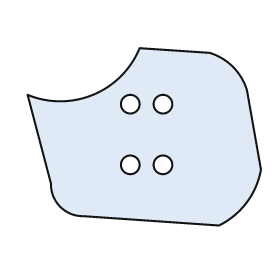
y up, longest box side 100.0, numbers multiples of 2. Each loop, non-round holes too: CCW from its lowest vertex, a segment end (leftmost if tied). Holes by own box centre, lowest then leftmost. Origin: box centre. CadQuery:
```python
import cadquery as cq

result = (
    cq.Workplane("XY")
    .moveTo(32.0, -38.0)
    .threePointArc((44.0, -28.0), (50.0, -14.0))
    .lineTo(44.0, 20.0)
    .threePointArc((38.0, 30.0), (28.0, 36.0))
    .lineTo(-2.0, 38.0)
    .threePointArc((-22.0, 18.0), (-50.0, 18.0))
    .lineTo(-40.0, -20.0)
    .threePointArc((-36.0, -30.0), (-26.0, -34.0))
    .close()
    .moveTo(-6.0, -12.0)
    .circle(4.0)
    .moveTo(8.0, -12.0)
    .circle(4.0)
    .moveTo(-6.0, 14.0)
    .circle(4.0)
    .moveTo(8.0, 14.0)
    .circle(4.0)
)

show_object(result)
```